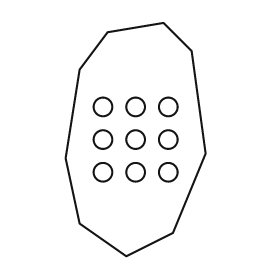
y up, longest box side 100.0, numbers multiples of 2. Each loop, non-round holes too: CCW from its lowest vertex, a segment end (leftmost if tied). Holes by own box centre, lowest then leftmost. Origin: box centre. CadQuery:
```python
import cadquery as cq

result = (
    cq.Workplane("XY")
    .moveTo(-4.0, -50.0)
    .lineTo(16.0, -40.0)
    .lineTo(30.0, -6.0)
    .lineTo(24.0, 38.0)
    .lineTo(12.0, 50.0)
    .lineTo(-12.0, 46.0)
    .lineTo(-24.0, 30.0)
    .lineTo(-30.0, -8.0)
    .lineTo(-24.0, -36.0)
    .close()
    .moveTo(-14.0, -14.0)
    .circle(4.0)
    .moveTo(0.0, -14.0)
    .circle(4.0)
    .moveTo(14.0, -14.0)
    .circle(4.0)
    .moveTo(-14.0, 0.0)
    .circle(4.0)
    .moveTo(0.0, 0.0)
    .circle(4.0)
    .moveTo(14.0, 0.0)
    .circle(4.0)
    .moveTo(-14.0, 14.0)
    .circle(4.0)
    .moveTo(0.0, 14.0)
    .circle(4.0)
    .moveTo(14.0, 14.0)
    .circle(4.0)
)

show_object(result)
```